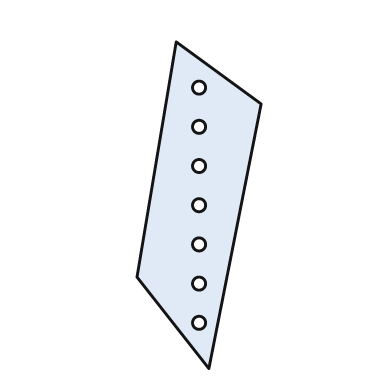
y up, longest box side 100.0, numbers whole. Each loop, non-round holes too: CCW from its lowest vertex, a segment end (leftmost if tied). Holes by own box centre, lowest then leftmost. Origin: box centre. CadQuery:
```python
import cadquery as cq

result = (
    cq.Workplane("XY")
    .moveTo(3.0, -50.0)
    .lineTo(19.0, 31.0)
    .lineTo(-7.0, 50.0)
    .lineTo(-19.0, -22.0)
    .close()
    .moveTo(0.0, -36.0)
    .circle(2.0)
    .moveTo(0.0, -24.0)
    .circle(2.0)
    .moveTo(0.0, -12.0)
    .circle(2.0)
    .moveTo(0.0, 0.0)
    .circle(2.0)
    .moveTo(0.0, 12.0)
    .circle(2.0)
    .moveTo(0.0, 24.0)
    .circle(2.0)
    .moveTo(0.0, 36.0)
    .circle(2.0)
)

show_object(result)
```